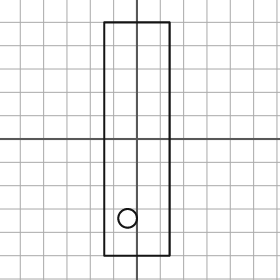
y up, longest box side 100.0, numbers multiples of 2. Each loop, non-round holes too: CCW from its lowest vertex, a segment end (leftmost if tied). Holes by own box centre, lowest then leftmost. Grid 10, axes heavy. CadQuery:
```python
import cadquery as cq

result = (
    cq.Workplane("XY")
    .moveTo(-14.0, -50.0)
    .lineTo(14.0, -50.0)
    .lineTo(14.0, 50.0)
    .lineTo(-14.0, 50.0)
    .close()
    .moveTo(-4.0, -34.0)
    .circle(4.0)
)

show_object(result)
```